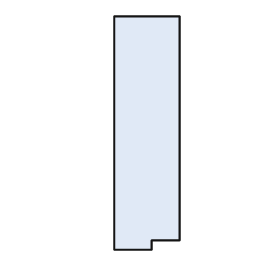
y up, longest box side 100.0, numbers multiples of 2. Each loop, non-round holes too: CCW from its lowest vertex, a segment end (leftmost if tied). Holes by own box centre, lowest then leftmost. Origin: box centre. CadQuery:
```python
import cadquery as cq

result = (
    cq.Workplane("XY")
    .moveTo(-14.0, -50.0)
    .lineTo(2.0, -50.0)
    .lineTo(2.0, -46.0)
    .lineTo(14.0, -46.0)
    .lineTo(14.0, 50.0)
    .lineTo(-14.0, 50.0)
    .close()
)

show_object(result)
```